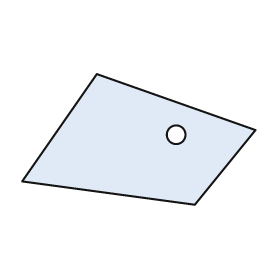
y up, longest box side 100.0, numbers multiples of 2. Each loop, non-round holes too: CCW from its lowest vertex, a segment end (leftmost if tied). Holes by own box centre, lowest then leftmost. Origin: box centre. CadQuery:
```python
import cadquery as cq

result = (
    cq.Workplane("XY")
    .moveTo(24.0, -28.0)
    .lineTo(50.0, 4.0)
    .lineTo(-18.0, 28.0)
    .lineTo(-50.0, -18.0)
    .close()
    .moveTo(16.0, 2.0)
    .circle(4.0)
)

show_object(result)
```